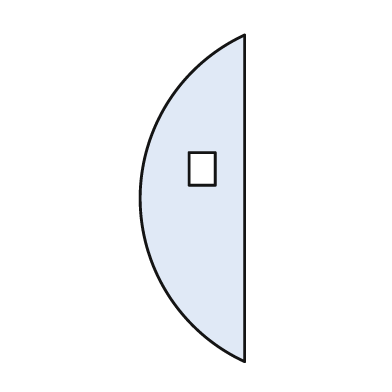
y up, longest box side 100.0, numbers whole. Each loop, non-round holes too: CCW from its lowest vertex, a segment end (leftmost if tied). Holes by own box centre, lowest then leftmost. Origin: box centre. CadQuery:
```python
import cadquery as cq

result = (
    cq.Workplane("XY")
    .moveTo(16.0, -50.0)
    .lineTo(16.0, 50.0)
    .threePointArc((-16.0, 0.0), (16.0, -50.0))
    .close()
    .moveTo(-1.0, 4.0)
    .lineTo(7.0, 4.0)
    .lineTo(7.0, 14.0)
    .lineTo(-1.0, 14.0)
    .close()
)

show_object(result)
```